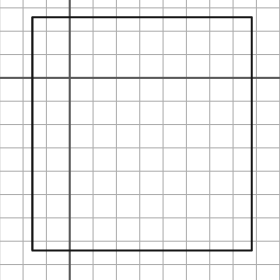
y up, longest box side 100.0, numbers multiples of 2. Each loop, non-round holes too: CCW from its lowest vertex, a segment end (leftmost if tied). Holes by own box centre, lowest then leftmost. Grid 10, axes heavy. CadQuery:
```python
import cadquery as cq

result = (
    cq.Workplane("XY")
    .moveTo(-16.0, -74.0)
    .lineTo(78.0, -74.0)
    .lineTo(78.0, 26.0)
    .lineTo(-16.0, 26.0)
    .close()
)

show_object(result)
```